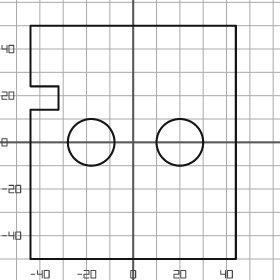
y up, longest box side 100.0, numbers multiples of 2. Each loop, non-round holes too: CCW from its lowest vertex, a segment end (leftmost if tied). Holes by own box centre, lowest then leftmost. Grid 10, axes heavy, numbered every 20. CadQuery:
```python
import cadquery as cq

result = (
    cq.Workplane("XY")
    .moveTo(-44.0, -50.0)
    .lineTo(44.0, -50.0)
    .lineTo(44.0, 50.0)
    .lineTo(-44.0, 50.0)
    .lineTo(-44.0, 24.0)
    .lineTo(-32.0, 24.0)
    .lineTo(-32.0, 14.0)
    .lineTo(-44.0, 14.0)
    .close()
    .moveTo(-18.0, 0.0)
    .circle(10.0)
    .moveTo(20.0, 0.0)
    .circle(10.0)
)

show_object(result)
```